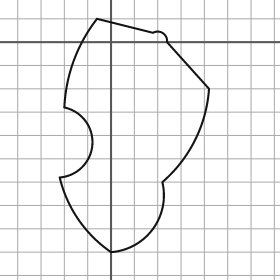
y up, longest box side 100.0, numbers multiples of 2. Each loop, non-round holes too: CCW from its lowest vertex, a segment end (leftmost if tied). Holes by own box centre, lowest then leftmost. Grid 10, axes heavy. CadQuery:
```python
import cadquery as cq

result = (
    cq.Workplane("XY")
    .moveTo(0.0, -90.0)
    .threePointArc((18.0, -80.0), (22.0, -60.0))
    .threePointArc((36.0, -42.0), (42.0, -20.0))
    .lineTo(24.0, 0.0)
    .threePointArc((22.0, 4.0), (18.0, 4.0))
    .lineTo(-6.0, 10.0)
    .threePointArc((-16.0, -8.0), (-20.0, -28.0))
    .threePointArc((-8.0, -44.0), (-22.0, -58.0))
    .threePointArc((-14.0, -76.0), (0.0, -90.0))
    .close()
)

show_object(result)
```